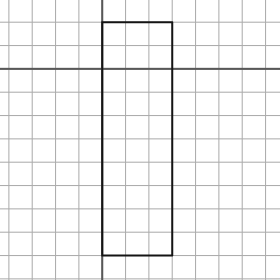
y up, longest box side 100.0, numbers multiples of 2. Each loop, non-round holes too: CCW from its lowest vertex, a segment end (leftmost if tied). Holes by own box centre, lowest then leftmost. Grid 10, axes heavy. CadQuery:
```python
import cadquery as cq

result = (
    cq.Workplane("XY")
    .moveTo(0.0, -80.0)
    .lineTo(30.0, -80.0)
    .lineTo(30.0, 20.0)
    .lineTo(0.0, 20.0)
    .close()
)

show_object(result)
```